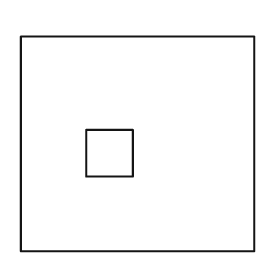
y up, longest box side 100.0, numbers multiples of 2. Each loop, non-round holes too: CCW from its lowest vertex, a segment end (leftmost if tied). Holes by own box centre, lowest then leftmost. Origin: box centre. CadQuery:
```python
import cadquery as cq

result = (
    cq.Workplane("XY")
    .moveTo(-50.0, -46.0)
    .lineTo(50.0, -46.0)
    .lineTo(50.0, 46.0)
    .lineTo(-50.0, 46.0)
    .close()
    .moveTo(-22.0, -14.0)
    .lineTo(-2.0, -14.0)
    .lineTo(-2.0, 6.0)
    .lineTo(-22.0, 6.0)
    .close()
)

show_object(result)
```